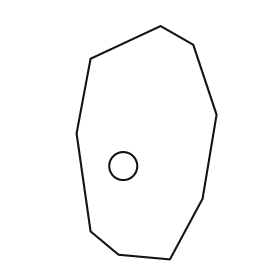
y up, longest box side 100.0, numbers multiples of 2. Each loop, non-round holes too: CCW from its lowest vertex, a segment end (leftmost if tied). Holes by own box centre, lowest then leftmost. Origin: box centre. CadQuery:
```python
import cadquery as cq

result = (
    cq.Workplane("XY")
    .moveTo(10.0, -50.0)
    .lineTo(24.0, -24.0)
    .lineTo(30.0, 12.0)
    .lineTo(20.0, 42.0)
    .lineTo(6.0, 50.0)
    .lineTo(-24.0, 36.0)
    .lineTo(-30.0, 4.0)
    .lineTo(-24.0, -38.0)
    .lineTo(-12.0, -48.0)
    .close()
    .moveTo(-10.0, -10.0)
    .circle(6.0)
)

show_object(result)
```